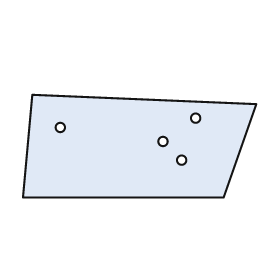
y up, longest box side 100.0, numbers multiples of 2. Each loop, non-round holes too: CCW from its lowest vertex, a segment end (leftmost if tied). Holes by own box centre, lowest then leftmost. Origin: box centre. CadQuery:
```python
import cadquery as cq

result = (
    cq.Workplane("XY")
    .moveTo(-50.0, -22.0)
    .lineTo(36.0, -22.0)
    .lineTo(50.0, 18.0)
    .lineTo(-46.0, 22.0)
    .close()
    .moveTo(18.0, -6.0)
    .circle(2.0)
    .moveTo(10.0, 2.0)
    .circle(2.0)
    .moveTo(-34.0, 8.0)
    .circle(2.0)
    .moveTo(24.0, 12.0)
    .circle(2.0)
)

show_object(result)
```